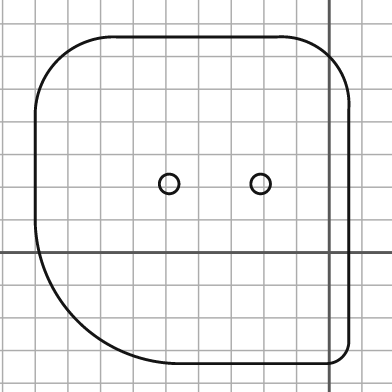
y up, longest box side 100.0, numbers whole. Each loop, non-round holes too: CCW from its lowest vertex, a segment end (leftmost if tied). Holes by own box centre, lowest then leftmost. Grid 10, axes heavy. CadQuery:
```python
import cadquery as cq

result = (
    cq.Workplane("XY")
    .moveTo(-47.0, -34.0)
    .lineTo(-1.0, -34.0)
    .threePointArc((4.0, -32.0), (6.0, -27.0))
    .lineTo(6.0, 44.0)
    .threePointArc((0.0, 60.0), (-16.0, 66.0))
    .lineTo(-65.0, 66.0)
    .threePointArc((-83.0, 59.0), (-90.0, 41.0))
    .lineTo(-90.0, 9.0)
    .threePointArc((-77.0, -21.0), (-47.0, -34.0))
    .close()
    .moveTo(-49.0, 21.0)
    .circle(3.0)
    .moveTo(-21.0, 21.0)
    .circle(3.0)
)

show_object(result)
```